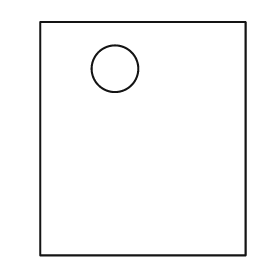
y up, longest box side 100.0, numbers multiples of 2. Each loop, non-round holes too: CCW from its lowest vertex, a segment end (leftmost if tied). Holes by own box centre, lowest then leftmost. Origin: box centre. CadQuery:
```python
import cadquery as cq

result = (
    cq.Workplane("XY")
    .moveTo(-44.0, -50.0)
    .lineTo(44.0, -50.0)
    .lineTo(44.0, 50.0)
    .lineTo(-44.0, 50.0)
    .close()
    .moveTo(-12.0, 30.0)
    .circle(10.0)
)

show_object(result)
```